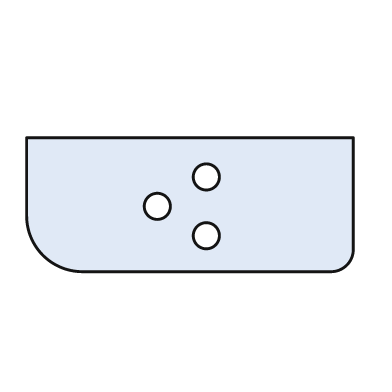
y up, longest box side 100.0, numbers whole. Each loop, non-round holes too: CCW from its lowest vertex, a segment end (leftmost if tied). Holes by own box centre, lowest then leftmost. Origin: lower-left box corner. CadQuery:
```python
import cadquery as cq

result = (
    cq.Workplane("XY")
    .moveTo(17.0, 0.0)
    .lineTo(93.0, 0.0)
    .threePointArc((98.0, 2.0), (100.0, 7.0))
    .lineTo(100.0, 41.0)
    .lineTo(0.0, 41.0)
    .lineTo(0.0, 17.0)
    .threePointArc((5.0, 5.0), (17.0, 0.0))
    .close()
    .moveTo(55.0, 11.0)
    .circle(4.0)
    .moveTo(40.0, 20.0)
    .circle(4.0)
    .moveTo(55.0, 29.0)
    .circle(4.0)
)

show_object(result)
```